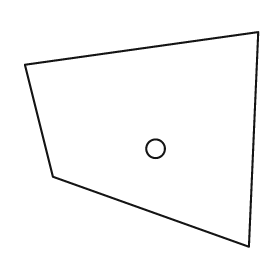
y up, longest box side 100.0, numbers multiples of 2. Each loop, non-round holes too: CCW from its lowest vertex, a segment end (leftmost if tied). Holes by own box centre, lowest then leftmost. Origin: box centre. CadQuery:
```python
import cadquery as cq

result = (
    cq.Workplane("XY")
    .moveTo(46.0, -46.0)
    .lineTo(50.0, 46.0)
    .lineTo(-50.0, 32.0)
    .lineTo(-38.0, -16.0)
    .close()
    .moveTo(6.0, -4.0)
    .circle(4.0)
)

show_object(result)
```